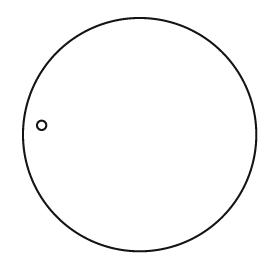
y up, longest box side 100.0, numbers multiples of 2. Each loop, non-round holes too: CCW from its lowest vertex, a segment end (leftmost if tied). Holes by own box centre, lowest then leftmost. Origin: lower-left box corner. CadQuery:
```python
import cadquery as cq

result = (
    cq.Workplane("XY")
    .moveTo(50.0, 50.0)
    .circle(50.0)
    .moveTo(8.0, 54.0)
    .circle(2.0)
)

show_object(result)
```